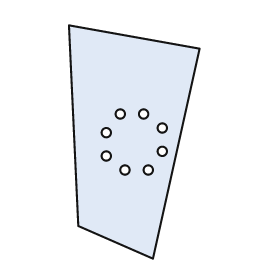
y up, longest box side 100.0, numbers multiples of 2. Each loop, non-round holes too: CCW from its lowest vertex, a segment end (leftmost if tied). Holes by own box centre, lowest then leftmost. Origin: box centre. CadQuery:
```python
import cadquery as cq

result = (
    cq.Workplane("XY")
    .moveTo(8.0, -50.0)
    .lineTo(28.0, 40.0)
    .lineTo(-28.0, 50.0)
    .lineTo(-24.0, -36.0)
    .close()
    .moveTo(-4.0, -12.0)
    .circle(2.0)
    .moveTo(6.0, -12.0)
    .circle(2.0)
    .moveTo(-12.0, -6.0)
    .circle(2.0)
    .moveTo(12.0, -4.0)
    .circle(2.0)
    .moveTo(-12.0, 4.0)
    .circle(2.0)
    .moveTo(12.0, 6.0)
    .circle(2.0)
    .moveTo(-6.0, 12.0)
    .circle(2.0)
    .moveTo(4.0, 12.0)
    .circle(2.0)
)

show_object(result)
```